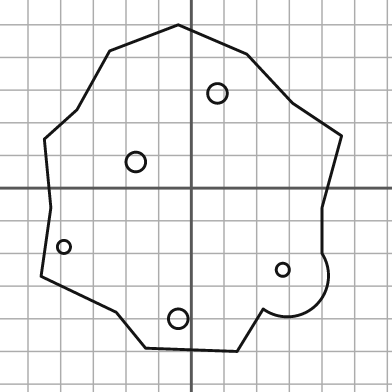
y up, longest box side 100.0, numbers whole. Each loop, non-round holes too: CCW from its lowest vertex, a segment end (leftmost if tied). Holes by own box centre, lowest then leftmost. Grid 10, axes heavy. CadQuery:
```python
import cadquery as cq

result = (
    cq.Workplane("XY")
    .moveTo(14.0, -50.0)
    .lineTo(22.0, -37.0)
    .threePointArc((38.0, -36.0), (40.0, -20.0))
    .lineTo(40.0, -6.0)
    .lineTo(46.0, 16.0)
    .lineTo(31.0, 26.0)
    .lineTo(17.0, 41.0)
    .lineTo(-4.0, 50.0)
    .lineTo(-25.0, 42.0)
    .lineTo(-35.0, 24.0)
    .lineTo(-45.0, 15.0)
    .lineTo(-43.0, -6.0)
    .lineTo(-46.0, -27.0)
    .lineTo(-23.0, -38.0)
    .lineTo(-14.0, -49.0)
    .close()
    .moveTo(-4.0, -40.0)
    .circle(3.0)
    .moveTo(28.0, -25.0)
    .circle(2.0)
    .moveTo(-39.0, -18.0)
    .circle(2.0)
    .moveTo(-17.0, 8.0)
    .circle(3.0)
    .moveTo(8.0, 29.0)
    .circle(3.0)
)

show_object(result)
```